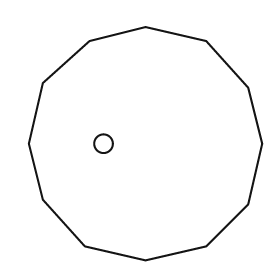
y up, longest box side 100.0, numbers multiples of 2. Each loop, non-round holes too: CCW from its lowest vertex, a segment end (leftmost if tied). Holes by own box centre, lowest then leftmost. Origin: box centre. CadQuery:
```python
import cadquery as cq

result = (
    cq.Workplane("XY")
    .moveTo(0.0, -50.0)
    .lineTo(26.0, -44.0)
    .lineTo(44.0, -26.0)
    .lineTo(50.0, 0.0)
    .lineTo(44.0, 24.0)
    .lineTo(26.0, 44.0)
    .lineTo(0.0, 50.0)
    .lineTo(-24.0, 44.0)
    .lineTo(-44.0, 26.0)
    .lineTo(-50.0, 0.0)
    .lineTo(-44.0, -24.0)
    .lineTo(-26.0, -44.0)
    .close()
    .moveTo(-18.0, 0.0)
    .circle(4.0)
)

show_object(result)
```